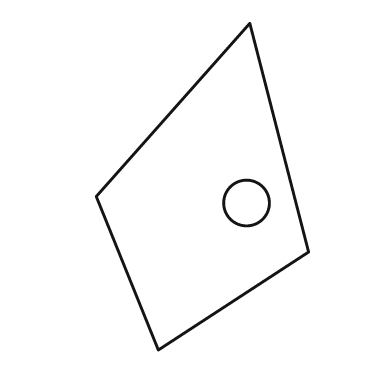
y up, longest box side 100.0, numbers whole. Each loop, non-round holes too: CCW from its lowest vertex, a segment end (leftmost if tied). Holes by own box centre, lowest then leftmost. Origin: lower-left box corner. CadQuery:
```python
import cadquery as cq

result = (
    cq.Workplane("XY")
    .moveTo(19.0, 0.0)
    .lineTo(65.0, 30.0)
    .lineTo(47.0, 100.0)
    .lineTo(0.0, 47.0)
    .close()
    .moveTo(46.0, 45.0)
    .circle(7.0)
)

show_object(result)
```